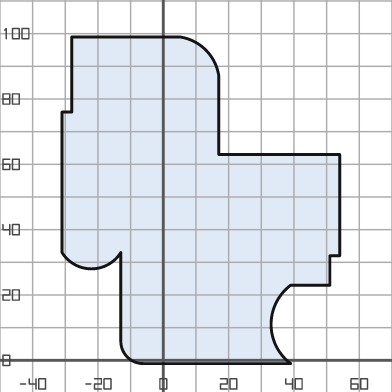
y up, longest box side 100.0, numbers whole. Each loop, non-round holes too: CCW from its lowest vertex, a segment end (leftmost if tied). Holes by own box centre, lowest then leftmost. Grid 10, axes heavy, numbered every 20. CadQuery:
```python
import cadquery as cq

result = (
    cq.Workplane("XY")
    .moveTo(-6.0, -1.0)
    .lineTo(39.0, -1.0)
    .threePointArc((33.0, 11.0), (39.0, 23.0))
    .lineTo(51.0, 23.0)
    .lineTo(51.0, 32.0)
    .lineTo(54.0, 32.0)
    .lineTo(54.0, 63.0)
    .lineTo(17.0, 63.0)
    .lineTo(17.0, 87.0)
    .threePointArc((13.0, 95.0), (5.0, 99.0))
    .lineTo(-28.0, 99.0)
    .lineTo(-28.0, 76.0)
    .lineTo(-31.0, 76.0)
    .lineTo(-31.0, 33.0)
    .threePointArc((-22.0, 28.0), (-13.0, 33.0))
    .lineTo(-13.0, 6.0)
    .threePointArc((-11.0, 1.0), (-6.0, -1.0))
    .close()
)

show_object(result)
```